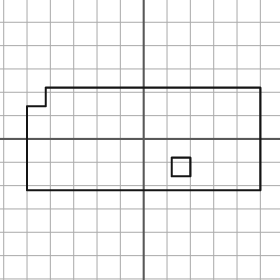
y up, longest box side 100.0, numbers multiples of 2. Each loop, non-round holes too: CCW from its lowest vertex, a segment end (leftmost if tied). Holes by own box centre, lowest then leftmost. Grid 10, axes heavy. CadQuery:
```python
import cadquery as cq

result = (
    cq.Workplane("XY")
    .moveTo(-50.0, -22.0)
    .lineTo(50.0, -22.0)
    .lineTo(50.0, 22.0)
    .lineTo(-42.0, 22.0)
    .lineTo(-42.0, 14.0)
    .lineTo(-50.0, 14.0)
    .close()
    .moveTo(12.0, -16.0)
    .lineTo(20.0, -16.0)
    .lineTo(20.0, -8.0)
    .lineTo(12.0, -8.0)
    .close()
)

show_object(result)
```